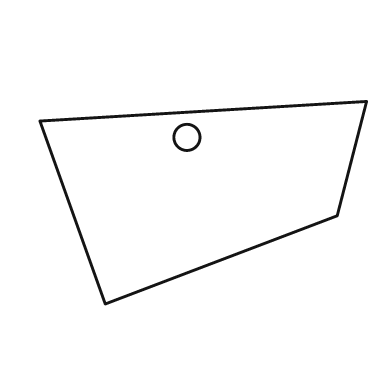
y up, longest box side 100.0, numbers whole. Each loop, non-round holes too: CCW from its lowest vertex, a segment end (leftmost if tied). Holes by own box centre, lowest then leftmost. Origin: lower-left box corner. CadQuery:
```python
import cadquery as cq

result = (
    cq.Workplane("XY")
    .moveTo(20.0, 0.0)
    .lineTo(91.0, 27.0)
    .lineTo(100.0, 62.0)
    .lineTo(0.0, 56.0)
    .close()
    .moveTo(45.0, 51.0)
    .circle(4.0)
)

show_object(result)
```